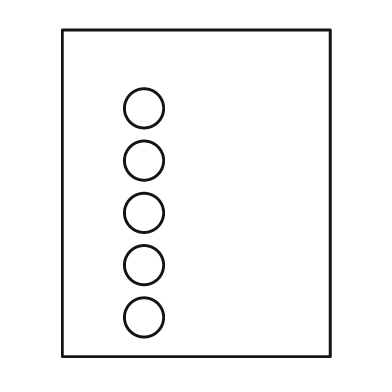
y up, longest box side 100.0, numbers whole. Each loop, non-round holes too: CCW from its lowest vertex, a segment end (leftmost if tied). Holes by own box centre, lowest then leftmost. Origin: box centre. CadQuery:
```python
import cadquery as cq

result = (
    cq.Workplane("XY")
    .moveTo(-41.0, -50.0)
    .lineTo(41.0, -50.0)
    .lineTo(41.0, 50.0)
    .lineTo(-41.0, 50.0)
    .close()
    .moveTo(-16.0, -38.0)
    .circle(6.0)
    .moveTo(-16.0, -22.0)
    .circle(6.0)
    .moveTo(-16.0, -6.0)
    .circle(6.0)
    .moveTo(-16.0, 10.0)
    .circle(6.0)
    .moveTo(-16.0, 26.0)
    .circle(6.0)
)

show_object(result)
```